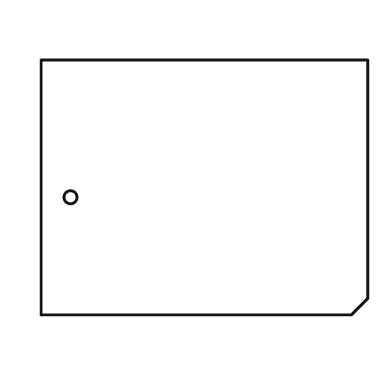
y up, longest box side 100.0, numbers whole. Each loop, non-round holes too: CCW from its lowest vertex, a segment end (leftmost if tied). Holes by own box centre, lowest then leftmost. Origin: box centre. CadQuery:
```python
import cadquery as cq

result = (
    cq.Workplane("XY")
    .moveTo(-50.0, -39.0)
    .lineTo(45.0, -39.0)
    .lineTo(50.0, -34.0)
    .lineTo(50.0, 39.0)
    .lineTo(-50.0, 39.0)
    .close()
    .moveTo(-41.0, -3.0)
    .circle(2.0)
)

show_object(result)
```